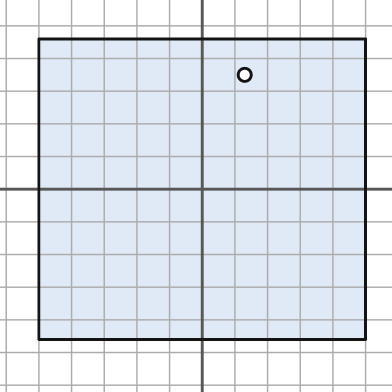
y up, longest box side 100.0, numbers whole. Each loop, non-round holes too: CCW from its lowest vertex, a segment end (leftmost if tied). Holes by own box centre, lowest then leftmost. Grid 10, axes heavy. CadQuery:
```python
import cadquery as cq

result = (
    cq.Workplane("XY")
    .moveTo(-50.0, -46.0)
    .lineTo(50.0, -46.0)
    .lineTo(50.0, 46.0)
    .lineTo(-50.0, 46.0)
    .close()
    .moveTo(13.0, 35.0)
    .circle(2.0)
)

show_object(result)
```